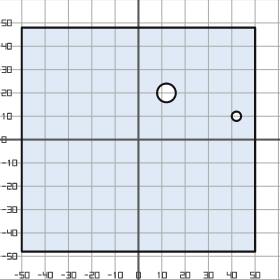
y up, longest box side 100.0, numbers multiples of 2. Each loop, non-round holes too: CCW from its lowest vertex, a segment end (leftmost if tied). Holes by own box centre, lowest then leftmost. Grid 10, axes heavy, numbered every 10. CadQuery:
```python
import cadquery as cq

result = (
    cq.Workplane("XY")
    .moveTo(-50.0, -48.0)
    .lineTo(50.0, -48.0)
    .lineTo(50.0, 48.0)
    .lineTo(-50.0, 48.0)
    .close()
    .moveTo(42.0, 10.0)
    .circle(2.0)
    .moveTo(12.0, 20.0)
    .circle(4.0)
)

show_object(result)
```